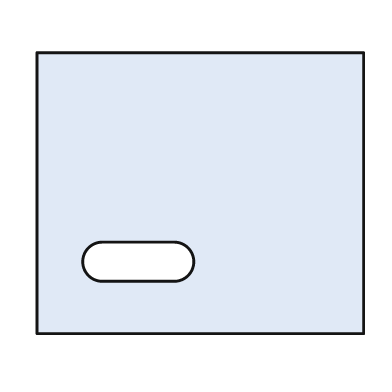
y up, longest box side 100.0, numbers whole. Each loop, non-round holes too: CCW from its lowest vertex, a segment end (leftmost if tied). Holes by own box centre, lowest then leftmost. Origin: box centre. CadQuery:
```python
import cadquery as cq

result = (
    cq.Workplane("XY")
    .moveTo(-50.0, -43.0)
    .lineTo(50.0, -43.0)
    .lineTo(50.0, 43.0)
    .lineTo(-50.0, 43.0)
    .close()
    .moveTo(-30.0, -27.0)
    .lineTo(-8.0, -27.0)
    .threePointArc((-2.0, -21.0), (-8.0, -15.0))
    .lineTo(-30.0, -15.0)
    .threePointArc((-36.0, -21.0), (-30.0, -27.0))
    .close()
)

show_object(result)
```